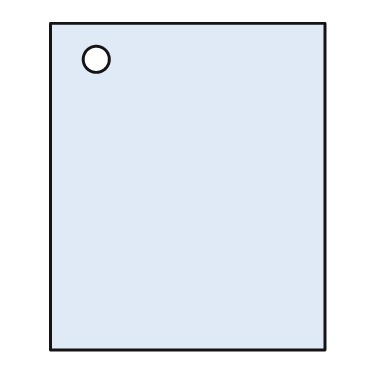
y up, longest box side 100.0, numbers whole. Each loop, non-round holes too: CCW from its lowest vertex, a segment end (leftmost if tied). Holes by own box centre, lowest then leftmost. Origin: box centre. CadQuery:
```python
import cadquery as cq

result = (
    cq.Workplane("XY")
    .moveTo(-42.0, -50.0)
    .lineTo(42.0, -50.0)
    .lineTo(42.0, 50.0)
    .lineTo(-42.0, 50.0)
    .close()
    .moveTo(-28.0, 39.0)
    .circle(4.0)
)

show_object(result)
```